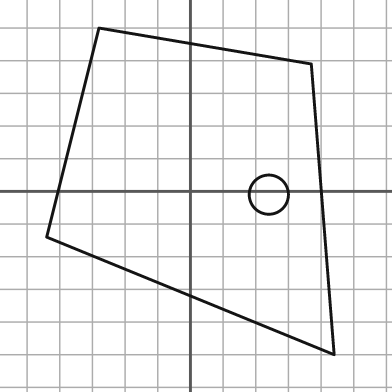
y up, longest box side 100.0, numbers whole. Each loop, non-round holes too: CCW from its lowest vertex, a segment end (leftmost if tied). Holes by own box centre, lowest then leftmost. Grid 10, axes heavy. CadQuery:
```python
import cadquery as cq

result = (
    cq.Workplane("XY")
    .moveTo(44.0, -50.0)
    .lineTo(37.0, 39.0)
    .lineTo(-28.0, 50.0)
    .lineTo(-44.0, -14.0)
    .close()
    .moveTo(24.0, -1.0)
    .circle(6.0)
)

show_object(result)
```